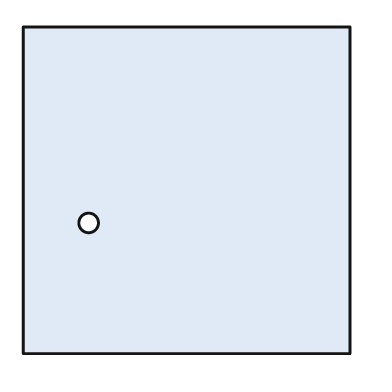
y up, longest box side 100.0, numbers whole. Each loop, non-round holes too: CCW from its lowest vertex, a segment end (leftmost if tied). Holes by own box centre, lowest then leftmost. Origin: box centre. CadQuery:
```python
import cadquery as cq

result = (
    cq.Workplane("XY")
    .moveTo(-50.0, -50.0)
    .lineTo(50.0, -50.0)
    .lineTo(50.0, 50.0)
    .lineTo(-50.0, 50.0)
    .close()
    .moveTo(-30.0, -10.0)
    .circle(3.0)
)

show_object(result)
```